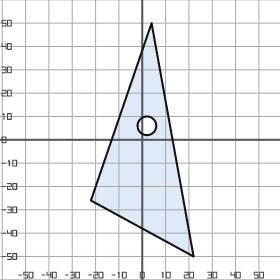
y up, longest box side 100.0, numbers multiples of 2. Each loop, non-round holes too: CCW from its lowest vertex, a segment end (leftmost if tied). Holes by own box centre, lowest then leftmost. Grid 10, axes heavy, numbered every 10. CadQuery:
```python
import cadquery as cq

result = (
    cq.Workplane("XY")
    .moveTo(22.0, -50.0)
    .lineTo(4.0, 50.0)
    .lineTo(-22.0, -26.0)
    .close()
    .moveTo(2.0, 6.0)
    .circle(4.0)
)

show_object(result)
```